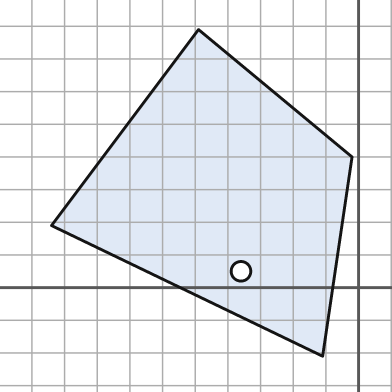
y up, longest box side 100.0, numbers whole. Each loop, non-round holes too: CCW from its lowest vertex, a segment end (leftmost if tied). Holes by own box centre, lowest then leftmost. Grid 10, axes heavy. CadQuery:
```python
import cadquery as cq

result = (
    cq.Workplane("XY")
    .moveTo(-11.0, -21.0)
    .lineTo(-2.0, 40.0)
    .lineTo(-49.0, 79.0)
    .lineTo(-94.0, 19.0)
    .close()
    .moveTo(-36.0, 5.0)
    .circle(3.0)
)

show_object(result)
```